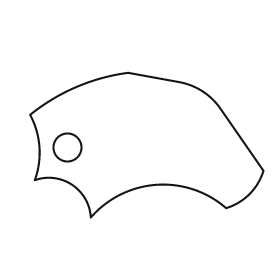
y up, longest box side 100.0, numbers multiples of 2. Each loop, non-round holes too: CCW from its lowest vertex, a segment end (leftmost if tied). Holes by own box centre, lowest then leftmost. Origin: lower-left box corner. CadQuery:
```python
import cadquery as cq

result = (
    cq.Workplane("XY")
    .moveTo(26.0, 0.0)
    .threePointArc((54.0, 14.0), (84.0, 4.0))
    .threePointArc((94.0, 10.0), (100.0, 20.0))
    .lineTo(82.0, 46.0)
    .threePointArc((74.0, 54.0), (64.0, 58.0))
    .lineTo(42.0, 62.0)
    .threePointArc((20.0, 56.0), (0.0, 44.0))
    .threePointArc((4.0, 30.0), (2.0, 16.0))
    .threePointArc((18.0, 14.0), (26.0, 0.0))
    .close()
    .moveTo(16.0, 30.0)
    .circle(6.0)
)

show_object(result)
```